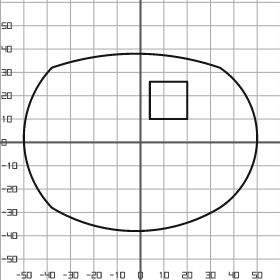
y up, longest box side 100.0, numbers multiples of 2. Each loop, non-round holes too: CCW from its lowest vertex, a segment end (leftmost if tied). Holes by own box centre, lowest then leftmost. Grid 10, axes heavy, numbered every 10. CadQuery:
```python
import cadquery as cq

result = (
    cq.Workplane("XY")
    .moveTo(-38.0, -28.0)
    .threePointArc((-2.0, -38.0), (34.0, -28.0))
    .threePointArc((50.0, 2.0), (34.0, 32.0))
    .threePointArc((-2.0, 38.0), (-38.0, 32.0))
    .threePointArc((-50.0, 2.0), (-38.0, -28.0))
    .close()
    .moveTo(4.0, 10.0)
    .lineTo(20.0, 10.0)
    .lineTo(20.0, 26.0)
    .lineTo(4.0, 26.0)
    .close()
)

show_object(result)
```